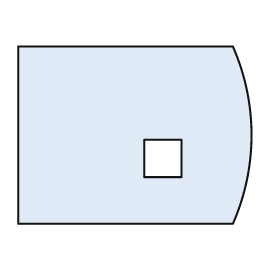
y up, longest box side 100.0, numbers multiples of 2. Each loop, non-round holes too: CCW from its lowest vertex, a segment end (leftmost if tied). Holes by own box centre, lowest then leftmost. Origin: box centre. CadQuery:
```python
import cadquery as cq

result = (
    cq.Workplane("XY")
    .moveTo(-50.0, -38.0)
    .lineTo(42.0, -38.0)
    .threePointArc((50.0, 0.0), (42.0, 38.0))
    .lineTo(-50.0, 38.0)
    .close()
    .moveTo(4.0, -18.0)
    .lineTo(20.0, -18.0)
    .lineTo(20.0, -2.0)
    .lineTo(4.0, -2.0)
    .close()
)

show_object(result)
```